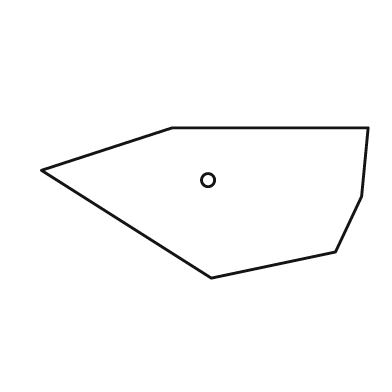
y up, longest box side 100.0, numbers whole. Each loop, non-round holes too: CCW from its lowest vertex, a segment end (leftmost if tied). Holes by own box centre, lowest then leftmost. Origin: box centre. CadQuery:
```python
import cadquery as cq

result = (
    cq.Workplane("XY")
    .moveTo(2.0, -23.0)
    .lineTo(40.0, -15.0)
    .lineTo(48.0, 2.0)
    .lineTo(50.0, 23.0)
    .lineTo(-10.0, 23.0)
    .lineTo(-50.0, 10.0)
    .close()
    .moveTo(1.0, 7.0)
    .circle(2.0)
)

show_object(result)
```